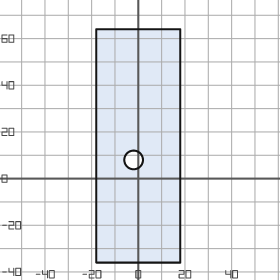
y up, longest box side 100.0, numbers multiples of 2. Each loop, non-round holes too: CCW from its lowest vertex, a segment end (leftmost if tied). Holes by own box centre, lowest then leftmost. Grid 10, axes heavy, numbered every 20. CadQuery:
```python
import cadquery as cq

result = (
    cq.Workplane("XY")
    .moveTo(-18.0, -36.0)
    .lineTo(18.0, -36.0)
    .lineTo(18.0, 64.0)
    .lineTo(-18.0, 64.0)
    .close()
    .moveTo(-2.0, 8.0)
    .circle(4.0)
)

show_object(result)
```